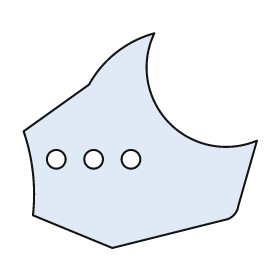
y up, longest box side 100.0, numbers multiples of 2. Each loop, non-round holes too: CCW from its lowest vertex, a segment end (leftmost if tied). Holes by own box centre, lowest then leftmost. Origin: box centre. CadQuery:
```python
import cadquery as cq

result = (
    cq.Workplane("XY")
    .moveTo(-12.0, -46.0)
    .lineTo(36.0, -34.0)
    .threePointArc((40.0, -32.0), (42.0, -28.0))
    .lineTo(50.0, 0.0)
    .threePointArc((12.0, 8.0), (6.0, 46.0))
    .threePointArc((-10.0, 38.0), (-22.0, 24.0))
    .lineTo(-50.0, 4.0)
    .threePointArc((-46.0, -14.0), (-46.0, -32.0))
    .close()
    .moveTo(-36.0, -8.0)
    .circle(4.0)
    .moveTo(-20.0, -8.0)
    .circle(4.0)
    .moveTo(-4.0, -8.0)
    .circle(4.0)
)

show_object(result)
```